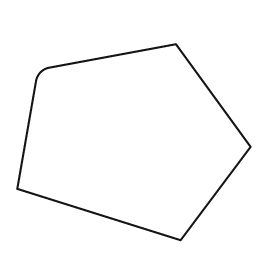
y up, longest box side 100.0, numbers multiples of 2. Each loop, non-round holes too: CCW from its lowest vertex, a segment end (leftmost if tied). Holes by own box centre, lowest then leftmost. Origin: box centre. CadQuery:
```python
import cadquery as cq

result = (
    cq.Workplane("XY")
    .moveTo(20.0, -42.0)
    .lineTo(50.0, -2.0)
    .lineTo(18.0, 42.0)
    .lineTo(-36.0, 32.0)
    .threePointArc((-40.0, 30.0), (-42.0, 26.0))
    .lineTo(-50.0, -20.0)
    .close()
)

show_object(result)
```